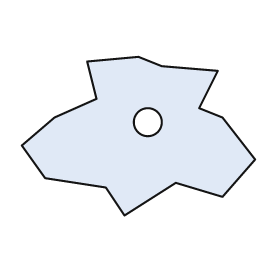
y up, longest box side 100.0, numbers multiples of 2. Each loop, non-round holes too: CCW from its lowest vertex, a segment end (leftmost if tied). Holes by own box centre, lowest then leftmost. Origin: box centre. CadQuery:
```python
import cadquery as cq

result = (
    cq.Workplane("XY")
    .moveTo(-6.0, -34.0)
    .lineTo(16.0, -20.0)
    .lineTo(36.0, -26.0)
    .lineTo(50.0, -10.0)
    .lineTo(36.0, 8.0)
    .lineTo(26.0, 12.0)
    .lineTo(34.0, 28.0)
    .lineTo(10.0, 30.0)
    .lineTo(0.0, 34.0)
    .lineTo(-22.0, 32.0)
    .lineTo(-18.0, 16.0)
    .lineTo(-36.0, 8.0)
    .lineTo(-50.0, -4.0)
    .lineTo(-40.0, -18.0)
    .lineTo(-14.0, -22.0)
    .close()
    .moveTo(4.0, 6.0)
    .circle(6.0)
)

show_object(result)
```